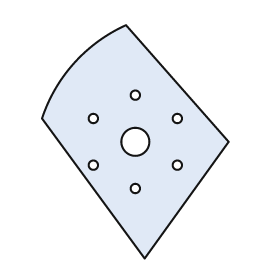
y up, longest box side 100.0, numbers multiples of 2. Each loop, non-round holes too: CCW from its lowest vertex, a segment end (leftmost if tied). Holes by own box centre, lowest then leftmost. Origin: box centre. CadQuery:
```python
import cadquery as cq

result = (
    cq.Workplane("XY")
    .moveTo(4.0, -50.0)
    .lineTo(40.0, 0.0)
    .lineTo(-4.0, 50.0)
    .threePointArc((-26.0, 34.0), (-40.0, 10.0))
    .close()
    .moveTo(0.0, -20.0)
    .circle(2.0)
    .moveTo(-18.0, -10.0)
    .circle(2.0)
    .moveTo(18.0, -10.0)
    .circle(2.0)
    .moveTo(0.0, 0.0)
    .circle(6.0)
    .moveTo(-18.0, 10.0)
    .circle(2.0)
    .moveTo(18.0, 10.0)
    .circle(2.0)
    .moveTo(0.0, 20.0)
    .circle(2.0)
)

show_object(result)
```